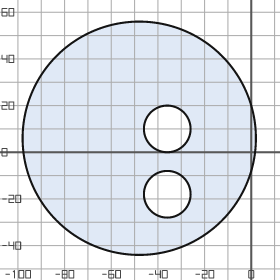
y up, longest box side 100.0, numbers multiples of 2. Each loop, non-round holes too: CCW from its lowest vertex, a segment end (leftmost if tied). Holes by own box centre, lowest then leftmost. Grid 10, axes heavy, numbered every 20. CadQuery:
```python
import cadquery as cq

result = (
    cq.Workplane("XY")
    .moveTo(-48.0, 6.0)
    .circle(50.0)
    .moveTo(-36.0, -18.0)
    .circle(10.0)
    .moveTo(-36.0, 10.0)
    .circle(10.0)
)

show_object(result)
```